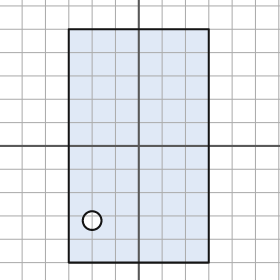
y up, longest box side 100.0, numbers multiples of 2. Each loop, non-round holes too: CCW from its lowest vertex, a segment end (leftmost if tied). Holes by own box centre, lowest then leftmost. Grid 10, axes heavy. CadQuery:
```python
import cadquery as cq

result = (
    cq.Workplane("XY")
    .moveTo(-30.0, -50.0)
    .lineTo(30.0, -50.0)
    .lineTo(30.0, 50.0)
    .lineTo(-30.0, 50.0)
    .close()
    .moveTo(-20.0, -32.0)
    .circle(4.0)
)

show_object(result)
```